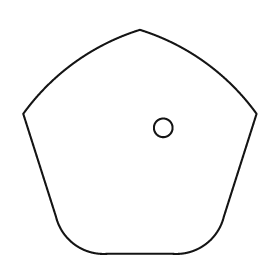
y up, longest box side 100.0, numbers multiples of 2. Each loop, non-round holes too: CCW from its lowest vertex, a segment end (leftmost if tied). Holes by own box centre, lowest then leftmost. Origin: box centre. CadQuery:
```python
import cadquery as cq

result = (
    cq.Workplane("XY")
    .moveTo(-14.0, -48.0)
    .lineTo(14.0, -48.0)
    .threePointArc((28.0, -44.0), (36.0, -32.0))
    .lineTo(50.0, 12.0)
    .threePointArc((28.0, 34.0), (0.0, 48.0))
    .threePointArc((-28.0, 34.0), (-50.0, 12.0))
    .lineTo(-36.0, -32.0)
    .threePointArc((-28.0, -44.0), (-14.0, -48.0))
    .close()
    .moveTo(10.0, 6.0)
    .circle(4.0)
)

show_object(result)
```